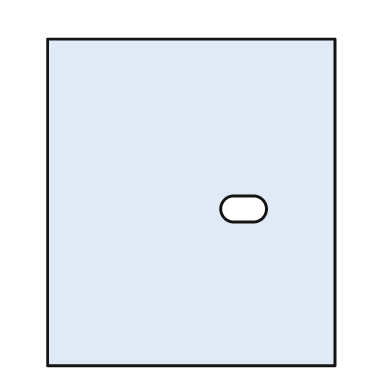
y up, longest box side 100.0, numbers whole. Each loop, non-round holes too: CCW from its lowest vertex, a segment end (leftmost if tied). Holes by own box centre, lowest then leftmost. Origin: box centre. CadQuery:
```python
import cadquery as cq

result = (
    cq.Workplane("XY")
    .moveTo(-44.0, -50.0)
    .lineTo(44.0, -50.0)
    .lineTo(44.0, 50.0)
    .lineTo(-44.0, 50.0)
    .close()
    .moveTo(13.0, -6.0)
    .lineTo(19.0, -6.0)
    .threePointArc((23.0, -2.0), (19.0, 2.0))
    .lineTo(13.0, 2.0)
    .threePointArc((9.0, -2.0), (13.0, -6.0))
    .close()
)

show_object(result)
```